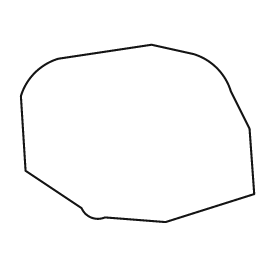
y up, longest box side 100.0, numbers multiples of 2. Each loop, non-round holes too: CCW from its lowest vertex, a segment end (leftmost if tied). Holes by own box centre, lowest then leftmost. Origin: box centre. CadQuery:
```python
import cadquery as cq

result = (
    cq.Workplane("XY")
    .moveTo(12.0, -38.0)
    .lineTo(50.0, -26.0)
    .lineTo(48.0, 2.0)
    .lineTo(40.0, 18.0)
    .threePointArc((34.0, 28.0), (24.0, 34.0))
    .lineTo(6.0, 38.0)
    .lineTo(-34.0, 32.0)
    .threePointArc((-44.0, 26.0), (-50.0, 16.0))
    .lineTo(-48.0, -16.0)
    .lineTo(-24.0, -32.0)
    .threePointArc((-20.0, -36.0), (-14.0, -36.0))
    .close()
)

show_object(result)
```